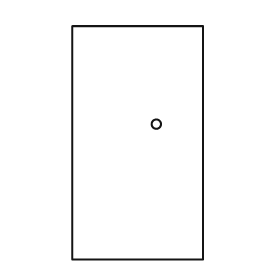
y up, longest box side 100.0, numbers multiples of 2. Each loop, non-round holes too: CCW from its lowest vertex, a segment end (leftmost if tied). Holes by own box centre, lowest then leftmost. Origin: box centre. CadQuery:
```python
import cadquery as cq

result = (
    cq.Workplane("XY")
    .moveTo(-28.0, -50.0)
    .lineTo(28.0, -50.0)
    .lineTo(28.0, 50.0)
    .lineTo(-28.0, 50.0)
    .close()
    .moveTo(8.0, 8.0)
    .circle(2.0)
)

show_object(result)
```